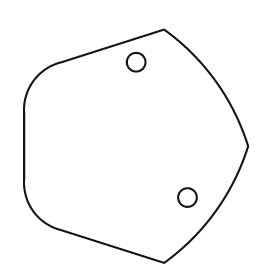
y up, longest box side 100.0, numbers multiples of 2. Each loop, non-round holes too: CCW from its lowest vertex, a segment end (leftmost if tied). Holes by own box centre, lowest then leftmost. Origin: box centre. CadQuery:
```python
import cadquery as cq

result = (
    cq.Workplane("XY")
    .moveTo(12.0, -50.0)
    .threePointArc((34.0, -28.0), (48.0, 0.0))
    .threePointArc((34.0, 28.0), (12.0, 50.0))
    .lineTo(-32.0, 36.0)
    .threePointArc((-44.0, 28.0), (-48.0, 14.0))
    .lineTo(-48.0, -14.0)
    .threePointArc((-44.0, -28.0), (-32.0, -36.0))
    .close()
    .moveTo(22.0, -22.0)
    .circle(4.0)
    .moveTo(0.0, 36.0)
    .circle(4.0)
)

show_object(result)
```